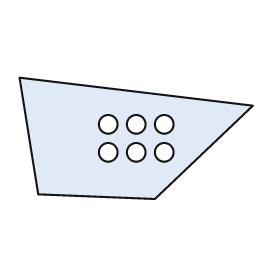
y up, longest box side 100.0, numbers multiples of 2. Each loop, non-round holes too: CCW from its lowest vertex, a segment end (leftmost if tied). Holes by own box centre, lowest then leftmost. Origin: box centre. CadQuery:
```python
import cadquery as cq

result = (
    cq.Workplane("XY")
    .moveTo(8.0, -26.0)
    .lineTo(50.0, 14.0)
    .lineTo(-50.0, 26.0)
    .lineTo(-42.0, -24.0)
    .close()
    .moveTo(-12.0, -6.0)
    .circle(4.0)
    .moveTo(0.0, -6.0)
    .circle(4.0)
    .moveTo(12.0, -6.0)
    .circle(4.0)
    .moveTo(-12.0, 6.0)
    .circle(4.0)
    .moveTo(0.0, 6.0)
    .circle(4.0)
    .moveTo(12.0, 6.0)
    .circle(4.0)
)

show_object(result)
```